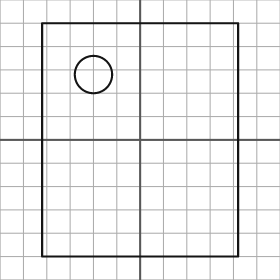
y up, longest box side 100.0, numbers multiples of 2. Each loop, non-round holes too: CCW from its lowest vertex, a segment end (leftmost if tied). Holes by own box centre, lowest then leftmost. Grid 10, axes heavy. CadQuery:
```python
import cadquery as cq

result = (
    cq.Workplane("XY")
    .moveTo(-42.0, -50.0)
    .lineTo(42.0, -50.0)
    .lineTo(42.0, 50.0)
    .lineTo(-42.0, 50.0)
    .close()
    .moveTo(-20.0, 28.0)
    .circle(8.0)
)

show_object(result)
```